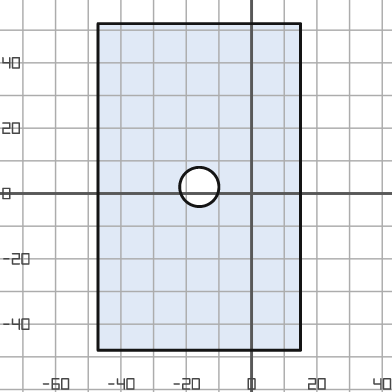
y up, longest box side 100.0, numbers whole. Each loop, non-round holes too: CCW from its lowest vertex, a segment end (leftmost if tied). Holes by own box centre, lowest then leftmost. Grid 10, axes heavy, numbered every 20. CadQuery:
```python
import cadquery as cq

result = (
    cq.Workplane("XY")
    .moveTo(-47.0, -48.0)
    .lineTo(15.0, -48.0)
    .lineTo(15.0, 52.0)
    .lineTo(-47.0, 52.0)
    .close()
    .moveTo(-16.0, 2.0)
    .circle(6.0)
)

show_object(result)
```